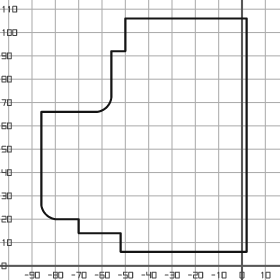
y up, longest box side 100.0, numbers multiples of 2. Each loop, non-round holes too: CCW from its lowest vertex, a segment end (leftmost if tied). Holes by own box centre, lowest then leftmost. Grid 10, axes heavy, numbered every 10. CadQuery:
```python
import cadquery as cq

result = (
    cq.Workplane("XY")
    .moveTo(-52.0, 6.0)
    .lineTo(2.0, 6.0)
    .lineTo(2.0, 106.0)
    .lineTo(-50.0, 106.0)
    .lineTo(-50.0, 92.0)
    .lineTo(-56.0, 92.0)
    .lineTo(-56.0, 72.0)
    .threePointArc((-58.0, 68.0), (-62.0, 66.0))
    .lineTo(-86.0, 66.0)
    .lineTo(-86.0, 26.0)
    .threePointArc((-84.0, 22.0), (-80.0, 20.0))
    .lineTo(-70.0, 20.0)
    .lineTo(-70.0, 14.0)
    .lineTo(-52.0, 14.0)
    .close()
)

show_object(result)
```